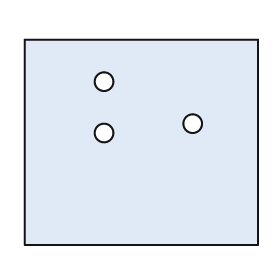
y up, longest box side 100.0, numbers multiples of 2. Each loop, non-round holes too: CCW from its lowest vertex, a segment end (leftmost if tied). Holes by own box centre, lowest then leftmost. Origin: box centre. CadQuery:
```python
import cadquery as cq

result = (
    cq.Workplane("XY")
    .moveTo(-50.0, -44.0)
    .lineTo(50.0, -44.0)
    .lineTo(50.0, 44.0)
    .lineTo(-50.0, 44.0)
    .close()
    .moveTo(-16.0, 4.0)
    .circle(4.0)
    .moveTo(22.0, 8.0)
    .circle(4.0)
    .moveTo(-16.0, 26.0)
    .circle(4.0)
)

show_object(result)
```